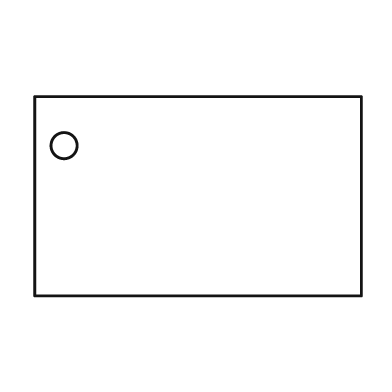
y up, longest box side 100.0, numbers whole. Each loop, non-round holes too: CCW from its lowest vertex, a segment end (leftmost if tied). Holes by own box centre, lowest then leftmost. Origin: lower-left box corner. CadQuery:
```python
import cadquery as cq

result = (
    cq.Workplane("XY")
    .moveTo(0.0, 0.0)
    .lineTo(100.0, 0.0)
    .lineTo(100.0, 61.0)
    .lineTo(0.0, 61.0)
    .close()
    .moveTo(9.0, 46.0)
    .circle(4.0)
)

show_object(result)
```